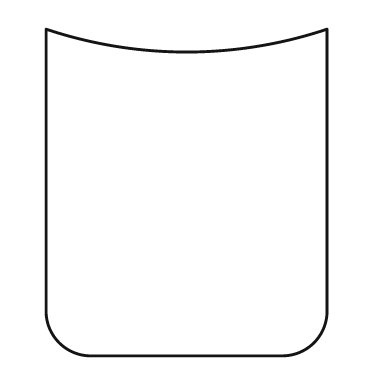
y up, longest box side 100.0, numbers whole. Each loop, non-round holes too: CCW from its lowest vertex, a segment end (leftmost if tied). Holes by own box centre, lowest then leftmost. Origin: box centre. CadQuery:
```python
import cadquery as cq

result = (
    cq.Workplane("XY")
    .moveTo(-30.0, -50.0)
    .lineTo(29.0, -50.0)
    .threePointArc((39.0, -46.0), (43.0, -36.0))
    .lineTo(43.0, 50.0)
    .threePointArc((0.0, 43.0), (-43.0, 50.0))
    .lineTo(-43.0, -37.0)
    .threePointArc((-39.0, -46.0), (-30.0, -50.0))
    .close()
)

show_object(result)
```